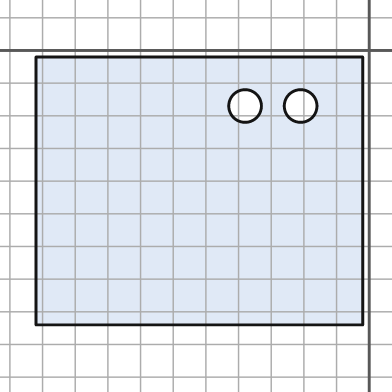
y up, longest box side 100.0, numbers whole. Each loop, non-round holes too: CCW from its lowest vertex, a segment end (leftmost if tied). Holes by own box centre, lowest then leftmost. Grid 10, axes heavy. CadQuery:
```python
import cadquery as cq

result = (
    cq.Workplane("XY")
    .moveTo(-102.0, -84.0)
    .lineTo(-2.0, -84.0)
    .lineTo(-2.0, -2.0)
    .lineTo(-102.0, -2.0)
    .close()
    .moveTo(-38.0, -17.0)
    .circle(5.0)
    .moveTo(-21.0, -17.0)
    .circle(5.0)
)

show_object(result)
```